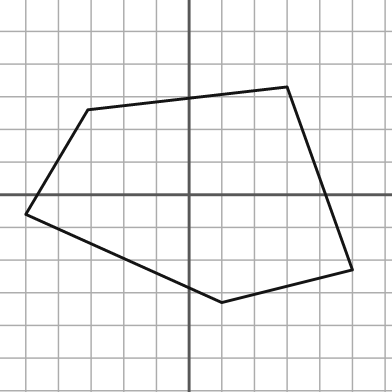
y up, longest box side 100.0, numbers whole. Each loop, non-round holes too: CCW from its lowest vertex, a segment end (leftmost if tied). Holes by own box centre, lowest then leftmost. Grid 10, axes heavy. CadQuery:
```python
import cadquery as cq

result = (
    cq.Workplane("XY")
    .moveTo(10.0, -33.0)
    .lineTo(50.0, -23.0)
    .lineTo(30.0, 33.0)
    .lineTo(-31.0, 26.0)
    .lineTo(-50.0, -6.0)
    .close()
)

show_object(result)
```